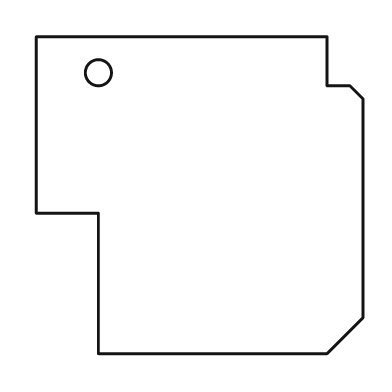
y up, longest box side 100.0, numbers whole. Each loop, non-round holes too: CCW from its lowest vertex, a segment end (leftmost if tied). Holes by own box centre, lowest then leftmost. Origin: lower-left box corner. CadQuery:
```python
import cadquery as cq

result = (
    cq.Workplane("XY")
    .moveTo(19.0, 0.0)
    .lineTo(89.0, 0.0)
    .lineTo(100.0, 11.0)
    .lineTo(100.0, 78.0)
    .lineTo(96.0, 82.0)
    .lineTo(89.0, 82.0)
    .lineTo(89.0, 97.0)
    .lineTo(0.0, 97.0)
    .lineTo(0.0, 43.0)
    .lineTo(19.0, 43.0)
    .close()
    .moveTo(19.0, 86.0)
    .circle(4.0)
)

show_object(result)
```